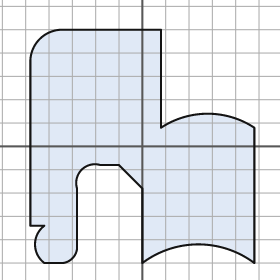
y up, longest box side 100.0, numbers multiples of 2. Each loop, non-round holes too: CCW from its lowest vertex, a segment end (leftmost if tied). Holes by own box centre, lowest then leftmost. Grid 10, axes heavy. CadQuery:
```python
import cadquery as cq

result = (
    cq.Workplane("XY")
    .moveTo(-42.0, -50.0)
    .lineTo(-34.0, -50.0)
    .threePointArc((-30.0, -48.0), (-28.0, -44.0))
    .lineTo(-28.0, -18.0)
    .threePointArc((-26.0, -10.0), (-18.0, -8.0))
    .lineTo(-10.0, -8.0)
    .lineTo(0.0, -18.0)
    .lineTo(0.0, -50.0)
    .threePointArc((24.0, -42.0), (48.0, -50.0))
    .lineTo(48.0, 8.0)
    .threePointArc((28.0, 14.0), (8.0, 8.0))
    .lineTo(8.0, 50.0)
    .lineTo(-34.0, 50.0)
    .threePointArc((-44.0, 46.0), (-48.0, 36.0))
    .lineTo(-48.0, -34.0)
    .lineTo(-42.0, -34.0)
    .threePointArc((-46.0, -42.0), (-42.0, -50.0))
    .close()
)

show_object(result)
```